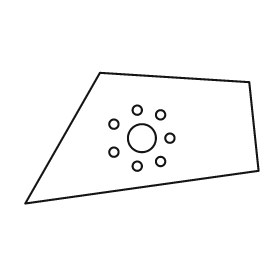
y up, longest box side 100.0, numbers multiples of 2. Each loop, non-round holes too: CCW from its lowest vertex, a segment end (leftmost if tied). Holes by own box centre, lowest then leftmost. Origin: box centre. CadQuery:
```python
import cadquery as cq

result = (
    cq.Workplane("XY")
    .moveTo(-50.0, -28.0)
    .lineTo(50.0, -14.0)
    .lineTo(46.0, 24.0)
    .lineTo(-18.0, 28.0)
    .close()
    .moveTo(-2.0, -12.0)
    .circle(2.0)
    .moveTo(8.0, -10.0)
    .circle(2.0)
    .moveTo(-12.0, -6.0)
    .circle(2.0)
    .moveTo(0.0, 0.0)
    .circle(6.0)
    .moveTo(12.0, 0.0)
    .circle(2.0)
    .moveTo(-12.0, 6.0)
    .circle(2.0)
    .moveTo(8.0, 10.0)
    .circle(2.0)
    .moveTo(-2.0, 12.0)
    .circle(2.0)
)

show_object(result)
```